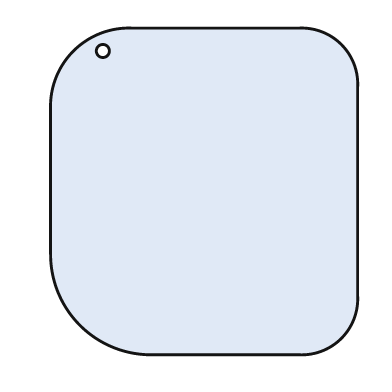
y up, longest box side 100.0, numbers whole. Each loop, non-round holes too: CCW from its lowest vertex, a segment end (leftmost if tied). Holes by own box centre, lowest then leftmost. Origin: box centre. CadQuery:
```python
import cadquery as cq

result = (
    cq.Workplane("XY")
    .moveTo(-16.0, -50.0)
    .lineTo(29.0, -50.0)
    .threePointArc((42.0, -45.0), (47.0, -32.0))
    .lineTo(47.0, 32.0)
    .threePointArc((42.0, 45.0), (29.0, 50.0))
    .lineTo(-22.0, 50.0)
    .threePointArc((-40.0, 43.0), (-47.0, 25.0))
    .lineTo(-47.0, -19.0)
    .threePointArc((-38.0, -41.0), (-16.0, -50.0))
    .close()
    .moveTo(-31.0, 43.0)
    .circle(2.0)
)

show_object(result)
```